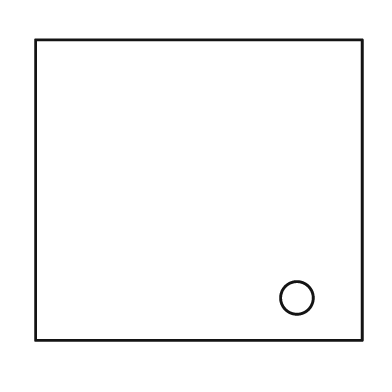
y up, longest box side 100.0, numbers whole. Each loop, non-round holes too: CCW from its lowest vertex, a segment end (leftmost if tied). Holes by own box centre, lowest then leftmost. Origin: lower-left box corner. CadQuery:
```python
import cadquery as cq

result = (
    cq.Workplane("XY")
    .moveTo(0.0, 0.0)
    .lineTo(100.0, 0.0)
    .lineTo(100.0, 92.0)
    .lineTo(0.0, 92.0)
    .close()
    .moveTo(80.0, 13.0)
    .circle(5.0)
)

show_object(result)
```